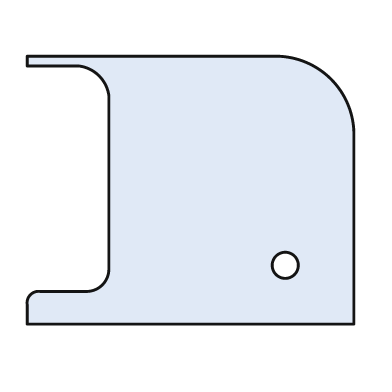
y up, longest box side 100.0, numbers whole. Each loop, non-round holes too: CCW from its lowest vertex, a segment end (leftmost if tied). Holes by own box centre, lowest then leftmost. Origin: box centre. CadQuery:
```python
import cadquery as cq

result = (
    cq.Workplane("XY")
    .moveTo(-50.0, -41.0)
    .lineTo(50.0, -41.0)
    .lineTo(50.0, 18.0)
    .threePointArc((43.0, 34.0), (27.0, 41.0))
    .lineTo(-50.0, 41.0)
    .lineTo(-50.0, 38.0)
    .lineTo(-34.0, 38.0)
    .threePointArc((-28.0, 35.0), (-25.0, 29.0))
    .lineTo(-25.0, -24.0)
    .threePointArc((-27.0, -29.0), (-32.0, -31.0))
    .lineTo(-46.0, -31.0)
    .threePointArc((-49.0, -32.0), (-50.0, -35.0))
    .close()
    .moveTo(29.0, -23.0)
    .circle(4.0)
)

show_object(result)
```